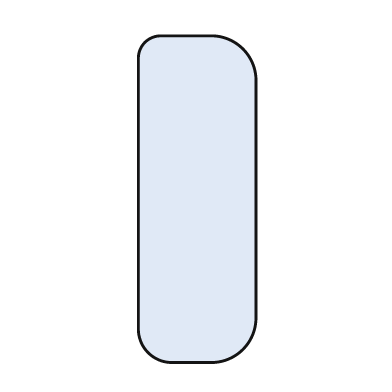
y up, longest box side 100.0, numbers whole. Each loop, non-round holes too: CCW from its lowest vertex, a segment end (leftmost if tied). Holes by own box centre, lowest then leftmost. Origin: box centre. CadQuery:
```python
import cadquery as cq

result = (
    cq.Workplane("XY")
    .moveTo(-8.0, -50.0)
    .lineTo(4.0, -50.0)
    .threePointArc((14.0, -46.0), (18.0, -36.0))
    .lineTo(18.0, 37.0)
    .threePointArc((14.0, 46.0), (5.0, 50.0))
    .lineTo(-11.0, 50.0)
    .threePointArc((-16.0, 48.0), (-18.0, 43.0))
    .lineTo(-18.0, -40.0)
    .threePointArc((-15.0, -47.0), (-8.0, -50.0))
    .close()
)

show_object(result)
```